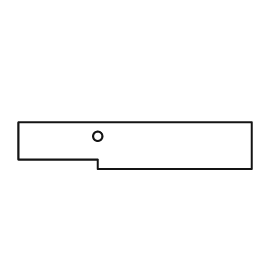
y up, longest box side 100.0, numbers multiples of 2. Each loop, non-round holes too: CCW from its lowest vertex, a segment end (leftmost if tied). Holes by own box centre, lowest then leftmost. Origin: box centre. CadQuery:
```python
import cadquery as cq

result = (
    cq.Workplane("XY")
    .moveTo(-16.0, -10.0)
    .lineTo(50.0, -10.0)
    .lineTo(50.0, 10.0)
    .lineTo(-50.0, 10.0)
    .lineTo(-50.0, -6.0)
    .lineTo(-16.0, -6.0)
    .close()
    .moveTo(-16.0, 4.0)
    .circle(2.0)
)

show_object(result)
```